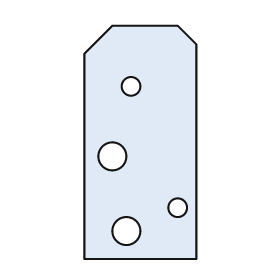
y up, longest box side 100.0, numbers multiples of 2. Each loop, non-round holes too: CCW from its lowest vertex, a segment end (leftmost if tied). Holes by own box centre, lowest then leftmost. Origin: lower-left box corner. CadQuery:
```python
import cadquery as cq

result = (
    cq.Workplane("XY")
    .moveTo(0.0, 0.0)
    .lineTo(48.0, 0.0)
    .lineTo(48.0, 92.0)
    .lineTo(40.0, 100.0)
    .lineTo(12.0, 100.0)
    .lineTo(0.0, 88.0)
    .close()
    .moveTo(18.0, 12.0)
    .circle(6.0)
    .moveTo(40.0, 22.0)
    .circle(4.0)
    .moveTo(12.0, 44.0)
    .circle(6.0)
    .moveTo(20.0, 74.0)
    .circle(4.0)
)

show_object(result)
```